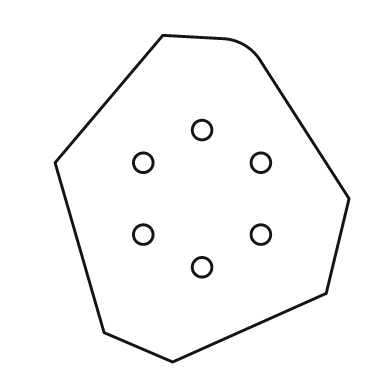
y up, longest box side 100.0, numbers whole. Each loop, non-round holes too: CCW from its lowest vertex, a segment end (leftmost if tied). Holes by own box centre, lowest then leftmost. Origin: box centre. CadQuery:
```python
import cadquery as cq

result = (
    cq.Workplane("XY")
    .moveTo(-9.0, -50.0)
    .lineTo(38.0, -29.0)
    .lineTo(45.0, 0.0)
    .lineTo(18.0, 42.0)
    .threePointArc((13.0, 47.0), (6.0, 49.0))
    .lineTo(-12.0, 50.0)
    .lineTo(-45.0, 11.0)
    .lineTo(-30.0, -41.0)
    .close()
    .moveTo(0.0, -21.0)
    .circle(3.0)
    .moveTo(-18.0, -11.0)
    .circle(3.0)
    .moveTo(18.0, -11.0)
    .circle(3.0)
    .moveTo(-18.0, 11.0)
    .circle(3.0)
    .moveTo(18.0, 11.0)
    .circle(3.0)
    .moveTo(0.0, 21.0)
    .circle(3.0)
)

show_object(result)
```